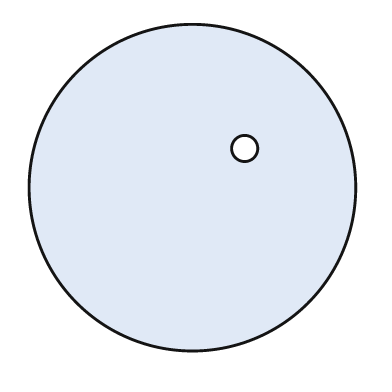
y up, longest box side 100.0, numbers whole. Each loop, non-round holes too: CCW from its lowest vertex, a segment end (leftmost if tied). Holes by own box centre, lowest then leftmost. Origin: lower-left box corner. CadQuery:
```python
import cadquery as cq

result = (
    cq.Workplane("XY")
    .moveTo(50.0, 50.0)
    .circle(50.0)
    .moveTo(66.0, 62.0)
    .circle(4.0)
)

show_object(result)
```